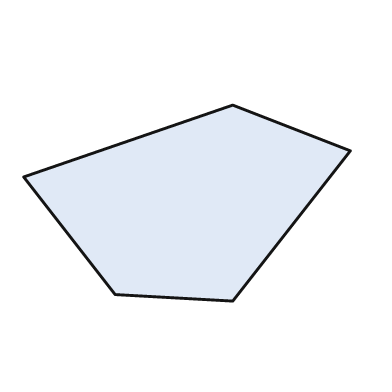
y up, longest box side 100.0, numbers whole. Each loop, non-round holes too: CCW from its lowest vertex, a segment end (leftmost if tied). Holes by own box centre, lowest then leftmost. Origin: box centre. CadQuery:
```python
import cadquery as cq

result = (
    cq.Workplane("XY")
    .moveTo(14.0, -30.0)
    .lineTo(50.0, 16.0)
    .lineTo(14.0, 30.0)
    .lineTo(-50.0, 8.0)
    .lineTo(-22.0, -28.0)
    .close()
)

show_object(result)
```